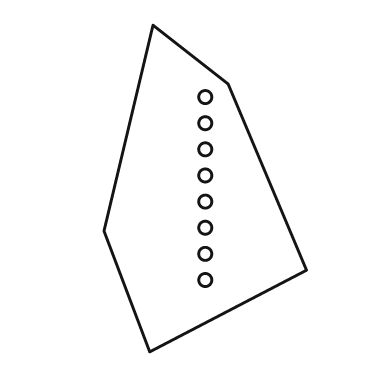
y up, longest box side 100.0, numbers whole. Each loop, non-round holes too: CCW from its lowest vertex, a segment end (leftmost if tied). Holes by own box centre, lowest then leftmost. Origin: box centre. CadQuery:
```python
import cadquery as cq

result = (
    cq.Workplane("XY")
    .moveTo(-17.0, -50.0)
    .lineTo(31.0, -25.0)
    .lineTo(7.0, 32.0)
    .lineTo(-16.0, 50.0)
    .lineTo(-31.0, -13.0)
    .close()
    .moveTo(0.0, -28.0)
    .circle(2.0)
    .moveTo(0.0, -20.0)
    .circle(2.0)
    .moveTo(0.0, -12.0)
    .circle(2.0)
    .moveTo(0.0, -4.0)
    .circle(2.0)
    .moveTo(0.0, 4.0)
    .circle(2.0)
    .moveTo(0.0, 12.0)
    .circle(2.0)
    .moveTo(0.0, 20.0)
    .circle(2.0)
    .moveTo(0.0, 28.0)
    .circle(2.0)
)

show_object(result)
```